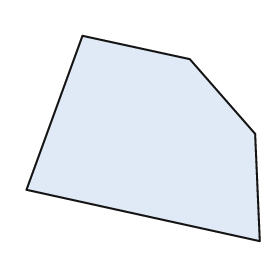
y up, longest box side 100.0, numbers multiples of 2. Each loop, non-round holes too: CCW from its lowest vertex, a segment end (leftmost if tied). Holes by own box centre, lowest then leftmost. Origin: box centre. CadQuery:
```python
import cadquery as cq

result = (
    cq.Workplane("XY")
    .moveTo(50.0, -44.0)
    .lineTo(48.0, 2.0)
    .lineTo(20.0, 34.0)
    .lineTo(-26.0, 44.0)
    .lineTo(-50.0, -22.0)
    .close()
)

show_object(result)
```